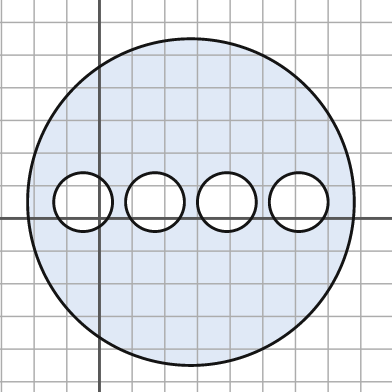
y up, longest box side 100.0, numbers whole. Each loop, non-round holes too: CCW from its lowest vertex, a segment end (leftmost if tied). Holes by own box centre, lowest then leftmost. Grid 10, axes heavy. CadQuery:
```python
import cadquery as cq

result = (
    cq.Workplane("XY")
    .moveTo(28.0, 5.0)
    .circle(50.0)
    .moveTo(-5.0, 5.0)
    .circle(9.0)
    .moveTo(17.0, 5.0)
    .circle(9.0)
    .moveTo(39.0, 5.0)
    .circle(9.0)
    .moveTo(61.0, 5.0)
    .circle(9.0)
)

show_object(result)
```